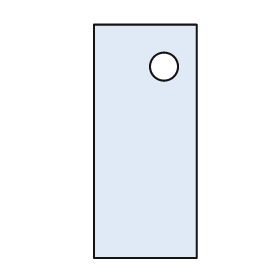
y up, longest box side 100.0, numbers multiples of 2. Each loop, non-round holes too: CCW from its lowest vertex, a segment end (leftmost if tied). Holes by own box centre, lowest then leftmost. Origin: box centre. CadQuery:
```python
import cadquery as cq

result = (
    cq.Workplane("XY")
    .moveTo(-22.0, -50.0)
    .lineTo(22.0, -50.0)
    .lineTo(22.0, 50.0)
    .lineTo(-22.0, 50.0)
    .close()
    .moveTo(8.0, 32.0)
    .circle(6.0)
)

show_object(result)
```